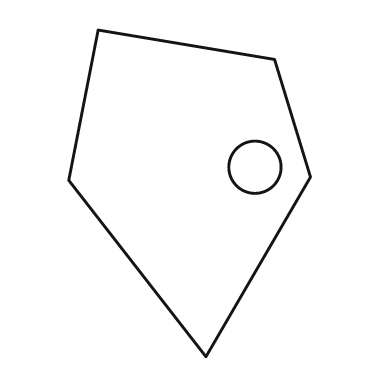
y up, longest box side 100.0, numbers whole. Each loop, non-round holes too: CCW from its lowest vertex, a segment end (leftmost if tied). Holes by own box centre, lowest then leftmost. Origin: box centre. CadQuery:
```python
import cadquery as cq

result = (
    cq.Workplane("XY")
    .moveTo(5.0, -50.0)
    .lineTo(37.0, 5.0)
    .lineTo(26.0, 41.0)
    .lineTo(-28.0, 50.0)
    .lineTo(-37.0, 4.0)
    .close()
    .moveTo(20.0, 8.0)
    .circle(8.0)
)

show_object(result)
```